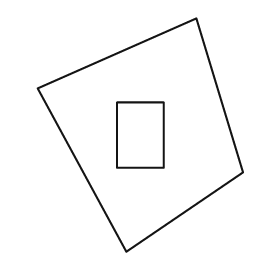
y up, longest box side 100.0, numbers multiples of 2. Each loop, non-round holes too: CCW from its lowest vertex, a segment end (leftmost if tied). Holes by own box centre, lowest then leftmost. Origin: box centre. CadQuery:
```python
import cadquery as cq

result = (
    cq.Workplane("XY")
    .moveTo(-6.0, -50.0)
    .lineTo(44.0, -16.0)
    .lineTo(24.0, 50.0)
    .lineTo(-44.0, 20.0)
    .close()
    .moveTo(-10.0, -14.0)
    .lineTo(10.0, -14.0)
    .lineTo(10.0, 14.0)
    .lineTo(-10.0, 14.0)
    .close()
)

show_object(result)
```